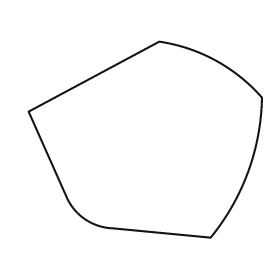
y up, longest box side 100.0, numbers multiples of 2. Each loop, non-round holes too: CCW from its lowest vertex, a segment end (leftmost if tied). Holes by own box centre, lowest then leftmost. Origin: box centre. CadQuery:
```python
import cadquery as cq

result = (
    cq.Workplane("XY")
    .moveTo(28.0, -42.0)
    .threePointArc((44.0, -14.0), (50.0, 18.0))
    .threePointArc((30.0, 34.0), (6.0, 42.0))
    .lineTo(-50.0, 12.0)
    .lineTo(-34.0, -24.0)
    .threePointArc((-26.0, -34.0), (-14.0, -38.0))
    .close()
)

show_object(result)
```